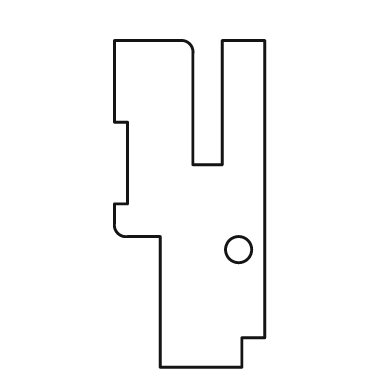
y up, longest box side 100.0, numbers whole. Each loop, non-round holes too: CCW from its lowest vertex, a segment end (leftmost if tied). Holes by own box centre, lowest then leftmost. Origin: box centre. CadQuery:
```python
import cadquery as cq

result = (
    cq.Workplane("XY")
    .moveTo(-9.0, -50.0)
    .lineTo(16.0, -50.0)
    .lineTo(16.0, -41.0)
    .lineTo(23.0, -41.0)
    .lineTo(23.0, 50.0)
    .lineTo(10.0, 50.0)
    .lineTo(10.0, 12.0)
    .lineTo(1.0, 12.0)
    .lineTo(1.0, 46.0)
    .threePointArc((0.0, 49.0), (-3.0, 50.0))
    .lineTo(-23.0, 50.0)
    .lineTo(-23.0, 25.0)
    .lineTo(-19.0, 25.0)
    .lineTo(-19.0, 0.0)
    .lineTo(-23.0, 0.0)
    .lineTo(-23.0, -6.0)
    .threePointArc((-22.0, -9.0), (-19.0, -10.0))
    .lineTo(-9.0, -10.0)
    .close()
    .moveTo(15.0, -14.0)
    .circle(4.0)
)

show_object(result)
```